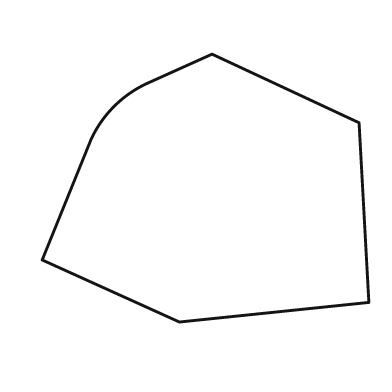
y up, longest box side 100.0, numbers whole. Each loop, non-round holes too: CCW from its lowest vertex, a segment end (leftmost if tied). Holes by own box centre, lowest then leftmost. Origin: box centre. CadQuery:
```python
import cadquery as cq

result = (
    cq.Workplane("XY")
    .moveTo(-8.0, -41.0)
    .lineTo(50.0, -35.0)
    .lineTo(47.0, 20.0)
    .lineTo(2.0, 41.0)
    .lineTo(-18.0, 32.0)
    .threePointArc((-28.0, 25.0), (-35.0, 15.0))
    .lineTo(-50.0, -22.0)
    .close()
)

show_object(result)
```